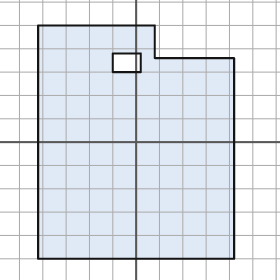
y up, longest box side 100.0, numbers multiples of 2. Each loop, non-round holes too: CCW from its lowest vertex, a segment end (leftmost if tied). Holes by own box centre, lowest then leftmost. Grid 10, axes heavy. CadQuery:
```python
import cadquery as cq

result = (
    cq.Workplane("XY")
    .moveTo(-42.0, -50.0)
    .lineTo(42.0, -50.0)
    .lineTo(42.0, 36.0)
    .lineTo(8.0, 36.0)
    .lineTo(8.0, 50.0)
    .lineTo(-42.0, 50.0)
    .close()
    .moveTo(-10.0, 30.0)
    .lineTo(2.0, 30.0)
    .lineTo(2.0, 38.0)
    .lineTo(-10.0, 38.0)
    .close()
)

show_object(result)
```